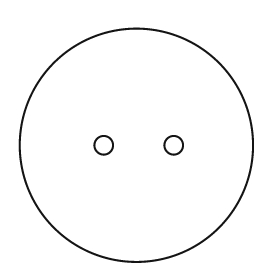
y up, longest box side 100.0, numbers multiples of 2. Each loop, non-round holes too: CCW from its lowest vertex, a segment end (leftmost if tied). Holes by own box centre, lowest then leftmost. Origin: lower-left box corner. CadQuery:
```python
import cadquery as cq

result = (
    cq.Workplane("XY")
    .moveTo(50.0, 50.0)
    .circle(50.0)
    .moveTo(36.0, 50.0)
    .circle(4.0)
    .moveTo(66.0, 50.0)
    .circle(4.0)
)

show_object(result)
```